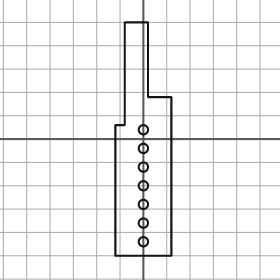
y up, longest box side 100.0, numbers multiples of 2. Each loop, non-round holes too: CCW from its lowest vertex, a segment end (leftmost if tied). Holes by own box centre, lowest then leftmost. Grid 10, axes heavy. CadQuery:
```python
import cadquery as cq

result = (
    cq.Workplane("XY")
    .moveTo(-12.0, -50.0)
    .lineTo(12.0, -50.0)
    .lineTo(12.0, 18.0)
    .lineTo(2.0, 18.0)
    .lineTo(2.0, 50.0)
    .lineTo(-8.0, 50.0)
    .lineTo(-8.0, 6.0)
    .lineTo(-12.0, 6.0)
    .close()
    .moveTo(0.0, -44.0)
    .circle(2.0)
    .moveTo(0.0, -36.0)
    .circle(2.0)
    .moveTo(0.0, -28.0)
    .circle(2.0)
    .moveTo(0.0, -20.0)
    .circle(2.0)
    .moveTo(0.0, -12.0)
    .circle(2.0)
    .moveTo(0.0, -4.0)
    .circle(2.0)
    .moveTo(0.0, 4.0)
    .circle(2.0)
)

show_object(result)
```